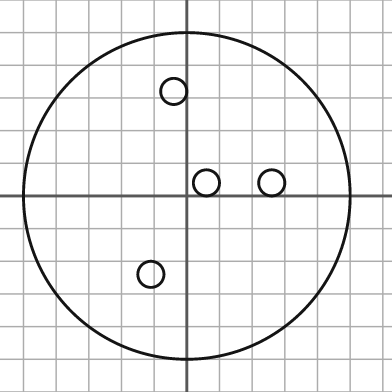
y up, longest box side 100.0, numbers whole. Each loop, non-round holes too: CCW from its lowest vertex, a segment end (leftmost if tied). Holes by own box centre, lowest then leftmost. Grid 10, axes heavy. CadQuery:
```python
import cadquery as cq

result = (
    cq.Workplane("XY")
    .moveTo(0.0, 0.0)
    .circle(50.0)
    .moveTo(-11.0, -24.0)
    .circle(4.0)
    .moveTo(6.0, 4.0)
    .circle(4.0)
    .moveTo(26.0, 4.0)
    .circle(4.0)
    .moveTo(-4.0, 32.0)
    .circle(4.0)
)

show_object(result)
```